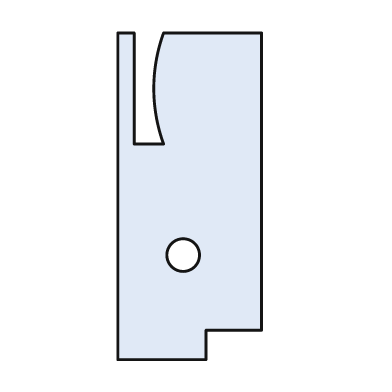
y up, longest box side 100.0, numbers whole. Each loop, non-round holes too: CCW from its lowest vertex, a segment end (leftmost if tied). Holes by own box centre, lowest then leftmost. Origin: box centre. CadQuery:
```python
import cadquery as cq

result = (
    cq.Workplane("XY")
    .moveTo(-22.0, -50.0)
    .lineTo(5.0, -50.0)
    .lineTo(5.0, -41.0)
    .lineTo(22.0, -41.0)
    .lineTo(22.0, 50.0)
    .lineTo(-8.0, 50.0)
    .threePointArc((-11.0, 33.0), (-8.0, 16.0))
    .lineTo(-17.0, 16.0)
    .lineTo(-17.0, 50.0)
    .lineTo(-22.0, 50.0)
    .close()
    .moveTo(-2.0, -18.0)
    .circle(5.0)
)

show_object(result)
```